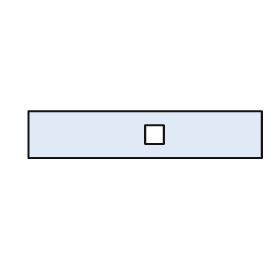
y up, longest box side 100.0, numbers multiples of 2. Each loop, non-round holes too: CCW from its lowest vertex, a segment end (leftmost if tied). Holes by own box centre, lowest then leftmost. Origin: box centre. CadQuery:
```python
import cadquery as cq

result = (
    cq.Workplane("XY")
    .moveTo(-50.0, -10.0)
    .lineTo(50.0, -10.0)
    .lineTo(50.0, 10.0)
    .lineTo(-50.0, 10.0)
    .close()
    .moveTo(0.0, -4.0)
    .lineTo(8.0, -4.0)
    .lineTo(8.0, 4.0)
    .lineTo(0.0, 4.0)
    .close()
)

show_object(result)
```